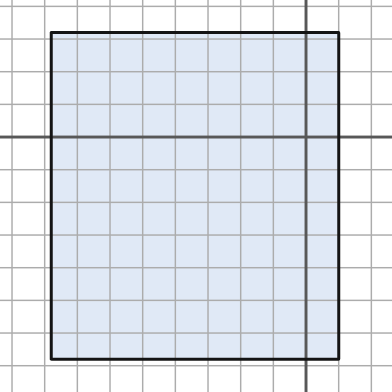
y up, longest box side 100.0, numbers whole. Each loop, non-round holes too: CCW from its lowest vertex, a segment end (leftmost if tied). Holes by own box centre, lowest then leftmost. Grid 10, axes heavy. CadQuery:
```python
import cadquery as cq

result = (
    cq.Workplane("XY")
    .moveTo(-78.0, -68.0)
    .lineTo(10.0, -68.0)
    .lineTo(10.0, 32.0)
    .lineTo(-78.0, 32.0)
    .close()
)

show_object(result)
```